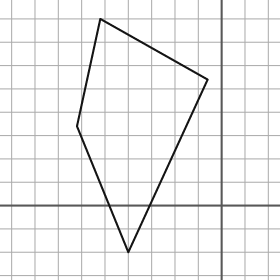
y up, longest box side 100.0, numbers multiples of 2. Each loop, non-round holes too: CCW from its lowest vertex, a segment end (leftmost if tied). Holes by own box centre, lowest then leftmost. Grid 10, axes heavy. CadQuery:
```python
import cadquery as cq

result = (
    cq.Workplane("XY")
    .moveTo(-40.0, -20.0)
    .lineTo(-6.0, 54.0)
    .lineTo(-52.0, 80.0)
    .lineTo(-62.0, 34.0)
    .close()
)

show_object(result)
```